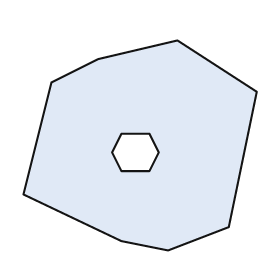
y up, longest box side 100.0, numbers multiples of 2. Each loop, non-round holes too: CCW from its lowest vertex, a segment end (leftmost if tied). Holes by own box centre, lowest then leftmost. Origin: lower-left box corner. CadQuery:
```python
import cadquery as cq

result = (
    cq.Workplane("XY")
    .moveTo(62.0, 0.0)
    .lineTo(88.0, 10.0)
    .lineTo(100.0, 68.0)
    .lineTo(66.0, 90.0)
    .lineTo(32.0, 82.0)
    .lineTo(12.0, 72.0)
    .lineTo(0.0, 24.0)
    .lineTo(42.0, 4.0)
    .close()
    .moveTo(42.0, 34.0)
    .lineTo(54.0, 34.0)
    .lineTo(58.0, 42.0)
    .lineTo(54.0, 50.0)
    .lineTo(42.0, 50.0)
    .lineTo(38.0, 42.0)
    .close()
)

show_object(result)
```